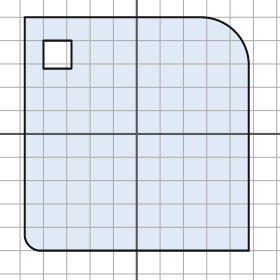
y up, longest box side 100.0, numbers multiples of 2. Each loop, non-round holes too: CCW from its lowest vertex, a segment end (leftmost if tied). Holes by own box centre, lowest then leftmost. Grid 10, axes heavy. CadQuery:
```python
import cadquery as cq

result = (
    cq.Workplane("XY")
    .moveTo(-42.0, -50.0)
    .lineTo(48.0, -50.0)
    .lineTo(48.0, 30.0)
    .threePointArc((42.0, 44.0), (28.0, 50.0))
    .lineTo(-48.0, 50.0)
    .lineTo(-48.0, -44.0)
    .threePointArc((-46.0, -48.0), (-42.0, -50.0))
    .close()
    .moveTo(-40.0, 28.0)
    .lineTo(-28.0, 28.0)
    .lineTo(-28.0, 40.0)
    .lineTo(-40.0, 40.0)
    .close()
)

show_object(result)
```